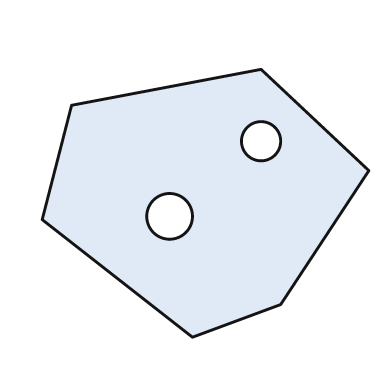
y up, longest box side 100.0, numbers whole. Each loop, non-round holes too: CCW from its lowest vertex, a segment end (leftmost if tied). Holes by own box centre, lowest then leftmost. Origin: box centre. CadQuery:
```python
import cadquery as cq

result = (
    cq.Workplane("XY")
    .moveTo(-4.0, -41.0)
    .lineTo(23.0, -31.0)
    .lineTo(50.0, 10.0)
    .lineTo(17.0, 41.0)
    .lineTo(-41.0, 30.0)
    .lineTo(-50.0, -5.0)
    .close()
    .moveTo(-11.0, -4.0)
    .circle(7.0)
    .moveTo(17.0, 19.0)
    .circle(6.0)
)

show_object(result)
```